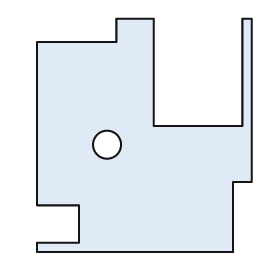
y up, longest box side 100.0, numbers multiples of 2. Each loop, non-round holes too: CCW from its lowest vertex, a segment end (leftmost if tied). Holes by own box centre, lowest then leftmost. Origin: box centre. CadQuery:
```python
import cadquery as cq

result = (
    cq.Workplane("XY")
    .moveTo(-46.0, -50.0)
    .lineTo(38.0, -50.0)
    .lineTo(38.0, -20.0)
    .lineTo(46.0, -20.0)
    .lineTo(46.0, 50.0)
    .lineTo(42.0, 50.0)
    .lineTo(42.0, 4.0)
    .lineTo(4.0, 4.0)
    .lineTo(4.0, 50.0)
    .lineTo(-12.0, 50.0)
    .lineTo(-12.0, 40.0)
    .lineTo(-46.0, 40.0)
    .lineTo(-46.0, -30.0)
    .lineTo(-28.0, -30.0)
    .lineTo(-28.0, -46.0)
    .lineTo(-46.0, -46.0)
    .close()
    .moveTo(-16.0, -4.0)
    .circle(6.0)
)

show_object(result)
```